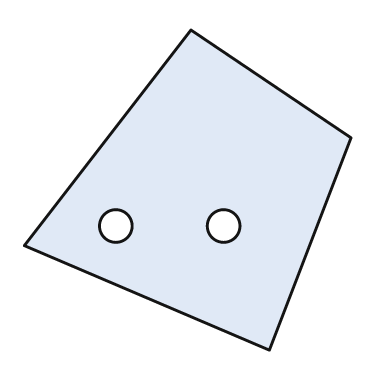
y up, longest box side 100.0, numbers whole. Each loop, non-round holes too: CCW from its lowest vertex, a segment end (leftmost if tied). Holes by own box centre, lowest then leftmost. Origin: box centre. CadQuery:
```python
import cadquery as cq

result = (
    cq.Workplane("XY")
    .moveTo(25.0, -49.0)
    .lineTo(50.0, 16.0)
    .lineTo(1.0, 49.0)
    .lineTo(-50.0, -17.0)
    .close()
    .moveTo(-22.0, -11.0)
    .circle(5.0)
    .moveTo(11.0, -11.0)
    .circle(5.0)
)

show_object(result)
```